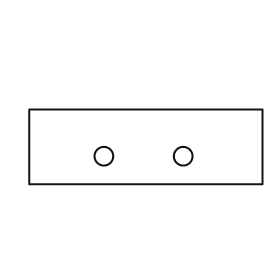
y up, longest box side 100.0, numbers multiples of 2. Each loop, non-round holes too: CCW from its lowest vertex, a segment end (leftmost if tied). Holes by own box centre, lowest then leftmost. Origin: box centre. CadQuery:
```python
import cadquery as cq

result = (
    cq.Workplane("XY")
    .moveTo(-50.0, -16.0)
    .lineTo(50.0, -16.0)
    .lineTo(50.0, 16.0)
    .lineTo(-50.0, 16.0)
    .close()
    .moveTo(-18.0, -4.0)
    .circle(4.0)
    .moveTo(16.0, -4.0)
    .circle(4.0)
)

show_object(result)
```